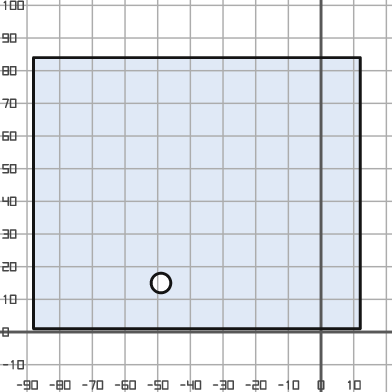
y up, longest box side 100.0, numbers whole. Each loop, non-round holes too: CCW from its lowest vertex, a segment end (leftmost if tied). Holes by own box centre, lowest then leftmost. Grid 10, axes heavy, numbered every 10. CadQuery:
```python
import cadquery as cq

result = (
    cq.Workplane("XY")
    .moveTo(-88.0, 1.0)
    .lineTo(12.0, 1.0)
    .lineTo(12.0, 84.0)
    .lineTo(-88.0, 84.0)
    .close()
    .moveTo(-49.0, 15.0)
    .circle(3.0)
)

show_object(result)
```